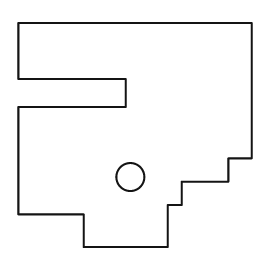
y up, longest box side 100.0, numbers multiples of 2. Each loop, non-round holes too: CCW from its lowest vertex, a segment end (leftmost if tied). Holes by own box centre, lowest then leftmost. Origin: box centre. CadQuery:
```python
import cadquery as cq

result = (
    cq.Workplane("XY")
    .moveTo(-22.0, -48.0)
    .lineTo(14.0, -48.0)
    .lineTo(14.0, -30.0)
    .lineTo(20.0, -30.0)
    .lineTo(20.0, -20.0)
    .lineTo(40.0, -20.0)
    .lineTo(40.0, -10.0)
    .lineTo(50.0, -10.0)
    .lineTo(50.0, 48.0)
    .lineTo(-50.0, 48.0)
    .lineTo(-50.0, 24.0)
    .lineTo(-4.0, 24.0)
    .lineTo(-4.0, 12.0)
    .lineTo(-50.0, 12.0)
    .lineTo(-50.0, -34.0)
    .lineTo(-22.0, -34.0)
    .close()
    .moveTo(-2.0, -18.0)
    .circle(6.0)
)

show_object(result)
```